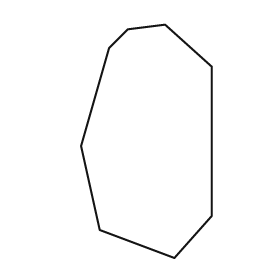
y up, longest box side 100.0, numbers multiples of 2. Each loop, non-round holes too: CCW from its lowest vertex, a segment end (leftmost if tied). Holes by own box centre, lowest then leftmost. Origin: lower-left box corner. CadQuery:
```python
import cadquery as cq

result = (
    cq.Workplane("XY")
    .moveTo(40.0, 0.0)
    .lineTo(56.0, 18.0)
    .lineTo(56.0, 82.0)
    .lineTo(36.0, 100.0)
    .lineTo(20.0, 98.0)
    .lineTo(12.0, 90.0)
    .lineTo(0.0, 48.0)
    .lineTo(8.0, 12.0)
    .close()
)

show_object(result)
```